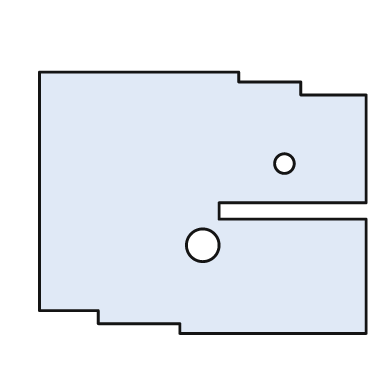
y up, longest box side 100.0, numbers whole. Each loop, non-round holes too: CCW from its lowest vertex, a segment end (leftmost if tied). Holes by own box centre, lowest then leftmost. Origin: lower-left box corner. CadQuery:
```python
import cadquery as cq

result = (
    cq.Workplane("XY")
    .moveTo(43.0, 0.0)
    .lineTo(100.0, 0.0)
    .lineTo(100.0, 35.0)
    .lineTo(55.0, 35.0)
    .lineTo(55.0, 40.0)
    .lineTo(100.0, 40.0)
    .lineTo(100.0, 73.0)
    .lineTo(80.0, 73.0)
    .lineTo(80.0, 77.0)
    .lineTo(61.0, 77.0)
    .lineTo(61.0, 80.0)
    .lineTo(0.0, 80.0)
    .lineTo(0.0, 7.0)
    .lineTo(18.0, 7.0)
    .lineTo(18.0, 3.0)
    .lineTo(43.0, 3.0)
    .close()
    .moveTo(50.0, 27.0)
    .circle(5.0)
    .moveTo(75.0, 52.0)
    .circle(3.0)
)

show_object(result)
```